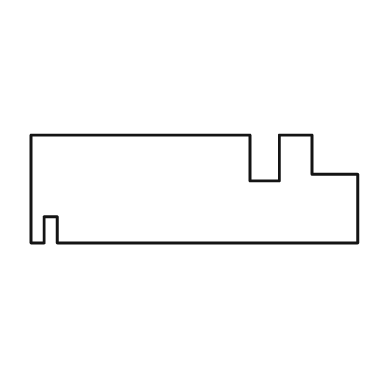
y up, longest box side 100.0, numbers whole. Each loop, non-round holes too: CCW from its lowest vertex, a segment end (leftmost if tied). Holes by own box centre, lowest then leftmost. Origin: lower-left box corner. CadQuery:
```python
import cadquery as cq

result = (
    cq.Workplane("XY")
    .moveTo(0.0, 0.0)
    .lineTo(4.0, 0.0)
    .lineTo(4.0, 8.0)
    .lineTo(8.0, 8.0)
    .lineTo(8.0, 0.0)
    .lineTo(100.0, 0.0)
    .lineTo(100.0, 21.0)
    .lineTo(86.0, 21.0)
    .lineTo(86.0, 33.0)
    .lineTo(76.0, 33.0)
    .lineTo(76.0, 19.0)
    .lineTo(67.0, 19.0)
    .lineTo(67.0, 33.0)
    .lineTo(0.0, 33.0)
    .close()
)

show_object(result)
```